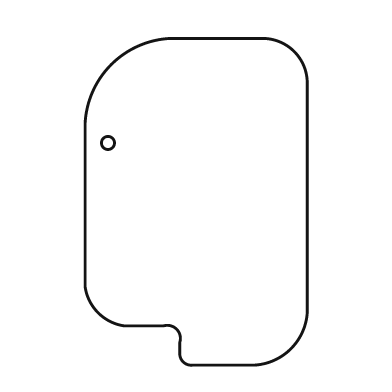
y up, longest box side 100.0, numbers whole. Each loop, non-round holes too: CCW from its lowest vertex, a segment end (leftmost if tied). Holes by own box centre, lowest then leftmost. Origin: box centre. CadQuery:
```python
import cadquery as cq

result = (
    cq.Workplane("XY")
    .moveTo(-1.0, -50.0)
    .lineTo(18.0, -50.0)
    .threePointArc((29.0, -45.0), (34.0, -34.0))
    .lineTo(34.0, 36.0)
    .threePointArc((30.0, 46.0), (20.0, 50.0))
    .lineTo(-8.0, 50.0)
    .threePointArc((-26.0, 42.0), (-34.0, 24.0))
    .lineTo(-34.0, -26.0)
    .threePointArc((-30.0, -34.0), (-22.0, -38.0))
    .lineTo(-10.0, -38.0)
    .threePointArc((-6.0, -39.0), (-5.0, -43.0))
    .lineTo(-5.0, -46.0)
    .threePointArc((-4.0, -49.0), (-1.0, -50.0))
    .close()
    .moveTo(-27.0, 18.0)
    .circle(2.0)
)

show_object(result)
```